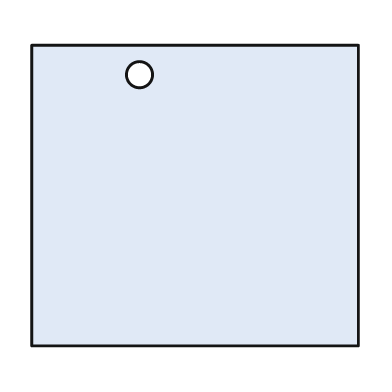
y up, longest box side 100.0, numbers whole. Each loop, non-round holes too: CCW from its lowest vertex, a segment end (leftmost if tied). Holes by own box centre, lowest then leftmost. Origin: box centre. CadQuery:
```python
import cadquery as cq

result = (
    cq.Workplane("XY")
    .moveTo(-50.0, -46.0)
    .lineTo(50.0, -46.0)
    .lineTo(50.0, 46.0)
    .lineTo(-50.0, 46.0)
    .close()
    .moveTo(-17.0, 37.0)
    .circle(4.0)
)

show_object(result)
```